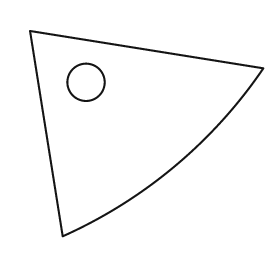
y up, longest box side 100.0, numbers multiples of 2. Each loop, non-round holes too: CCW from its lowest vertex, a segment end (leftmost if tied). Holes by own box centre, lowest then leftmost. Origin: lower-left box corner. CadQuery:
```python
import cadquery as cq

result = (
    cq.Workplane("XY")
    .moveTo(14.0, 0.0)
    .threePointArc((62.0, 30.0), (100.0, 72.0))
    .lineTo(0.0, 88.0)
    .close()
    .moveTo(24.0, 66.0)
    .circle(8.0)
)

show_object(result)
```